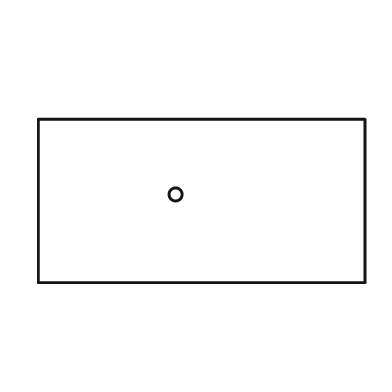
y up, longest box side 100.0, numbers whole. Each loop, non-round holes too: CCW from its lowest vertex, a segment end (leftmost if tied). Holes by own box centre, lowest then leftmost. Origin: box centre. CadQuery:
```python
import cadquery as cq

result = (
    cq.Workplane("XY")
    .moveTo(-50.0, -25.0)
    .lineTo(50.0, -25.0)
    .lineTo(50.0, 25.0)
    .lineTo(-50.0, 25.0)
    .close()
    .moveTo(-8.0, 2.0)
    .circle(2.0)
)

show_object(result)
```